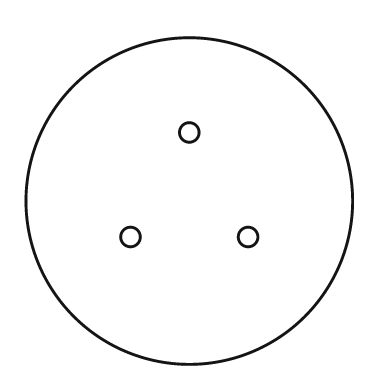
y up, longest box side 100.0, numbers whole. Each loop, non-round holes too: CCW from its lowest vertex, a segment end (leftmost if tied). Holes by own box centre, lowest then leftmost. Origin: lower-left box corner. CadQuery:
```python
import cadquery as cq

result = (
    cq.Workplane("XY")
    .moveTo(50.0, 50.0)
    .circle(50.0)
    .moveTo(32.0, 39.0)
    .circle(3.0)
    .moveTo(68.0, 39.0)
    .circle(3.0)
    .moveTo(50.0, 71.0)
    .circle(3.0)
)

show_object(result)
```